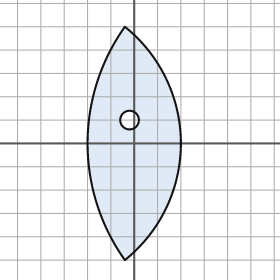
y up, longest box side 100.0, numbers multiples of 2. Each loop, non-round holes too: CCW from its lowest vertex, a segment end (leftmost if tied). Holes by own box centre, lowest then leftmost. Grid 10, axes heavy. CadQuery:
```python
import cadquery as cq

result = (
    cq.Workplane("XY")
    .moveTo(-4.0, -50.0)
    .threePointArc((20.0, 0.0), (-4.0, 50.0))
    .threePointArc((-20.0, 0.0), (-4.0, -50.0))
    .close()
    .moveTo(-2.0, 10.0)
    .circle(4.0)
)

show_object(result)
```